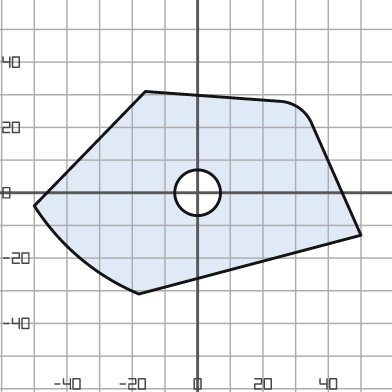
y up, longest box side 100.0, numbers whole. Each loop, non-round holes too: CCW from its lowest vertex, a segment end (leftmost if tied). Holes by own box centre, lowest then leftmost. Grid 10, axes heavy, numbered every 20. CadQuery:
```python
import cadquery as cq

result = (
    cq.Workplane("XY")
    .moveTo(-18.0, -31.0)
    .lineTo(50.0, -13.0)
    .lineTo(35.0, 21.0)
    .threePointArc((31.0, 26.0), (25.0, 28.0))
    .lineTo(-16.0, 31.0)
    .lineTo(-50.0, -4.0)
    .threePointArc((-36.0, -20.0), (-18.0, -31.0))
    .close()
    .moveTo(0.0, 0.0)
    .circle(7.0)
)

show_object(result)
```